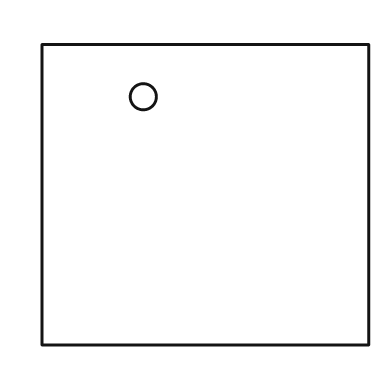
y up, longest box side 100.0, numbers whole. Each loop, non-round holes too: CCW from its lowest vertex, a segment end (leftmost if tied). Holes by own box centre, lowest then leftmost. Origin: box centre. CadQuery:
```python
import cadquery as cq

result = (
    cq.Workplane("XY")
    .moveTo(-50.0, -46.0)
    .lineTo(50.0, -46.0)
    .lineTo(50.0, 46.0)
    .lineTo(-50.0, 46.0)
    .close()
    .moveTo(-19.0, 30.0)
    .circle(4.0)
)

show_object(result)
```